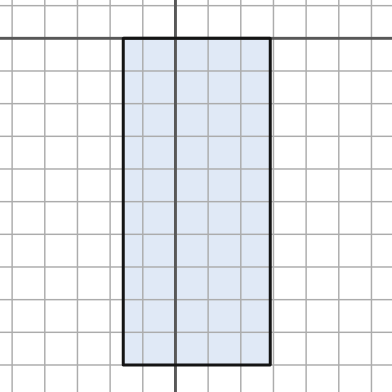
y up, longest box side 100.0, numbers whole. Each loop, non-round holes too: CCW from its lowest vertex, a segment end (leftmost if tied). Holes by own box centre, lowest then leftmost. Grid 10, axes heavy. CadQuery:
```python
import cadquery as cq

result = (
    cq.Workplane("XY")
    .moveTo(-16.0, -100.0)
    .lineTo(29.0, -100.0)
    .lineTo(29.0, 0.0)
    .lineTo(-16.0, 0.0)
    .close()
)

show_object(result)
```